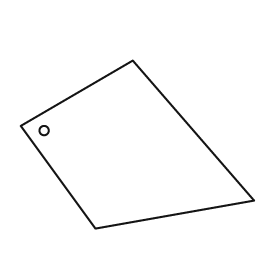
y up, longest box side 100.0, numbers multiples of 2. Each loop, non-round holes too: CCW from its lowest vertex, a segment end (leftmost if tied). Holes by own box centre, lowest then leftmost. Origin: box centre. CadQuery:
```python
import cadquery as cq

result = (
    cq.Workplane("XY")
    .moveTo(-18.0, -36.0)
    .lineTo(50.0, -24.0)
    .lineTo(-2.0, 36.0)
    .lineTo(-50.0, 8.0)
    .close()
    .moveTo(-40.0, 6.0)
    .circle(2.0)
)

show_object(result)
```